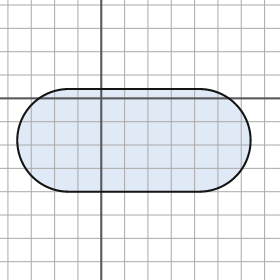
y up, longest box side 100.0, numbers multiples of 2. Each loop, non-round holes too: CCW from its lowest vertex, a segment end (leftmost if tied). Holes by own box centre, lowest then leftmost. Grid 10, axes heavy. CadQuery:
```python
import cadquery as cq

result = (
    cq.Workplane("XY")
    .moveTo(-14.0, -40.0)
    .lineTo(42.0, -40.0)
    .threePointArc((64.0, -18.0), (42.0, 4.0))
    .lineTo(-14.0, 4.0)
    .threePointArc((-36.0, -18.0), (-14.0, -40.0))
    .close()
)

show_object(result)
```